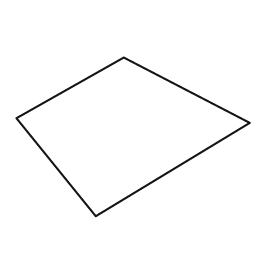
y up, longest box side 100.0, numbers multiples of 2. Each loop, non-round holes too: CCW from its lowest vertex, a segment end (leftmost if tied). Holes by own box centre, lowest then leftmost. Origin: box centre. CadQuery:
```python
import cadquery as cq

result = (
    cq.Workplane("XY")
    .moveTo(-16.0, -34.0)
    .lineTo(50.0, 6.0)
    .lineTo(-4.0, 34.0)
    .lineTo(-50.0, 8.0)
    .close()
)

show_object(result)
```